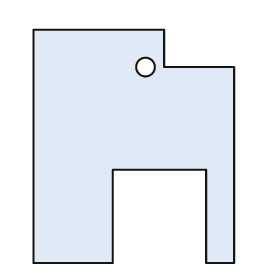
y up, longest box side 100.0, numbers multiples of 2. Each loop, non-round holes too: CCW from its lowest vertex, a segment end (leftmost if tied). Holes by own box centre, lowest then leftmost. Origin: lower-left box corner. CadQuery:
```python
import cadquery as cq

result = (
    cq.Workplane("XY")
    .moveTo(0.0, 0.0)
    .lineTo(34.0, 0.0)
    .lineTo(34.0, 40.0)
    .lineTo(74.0, 40.0)
    .lineTo(74.0, 0.0)
    .lineTo(86.0, 0.0)
    .lineTo(86.0, 84.0)
    .lineTo(56.0, 84.0)
    .lineTo(56.0, 100.0)
    .lineTo(0.0, 100.0)
    .close()
    .moveTo(48.0, 84.0)
    .circle(4.0)
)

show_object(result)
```